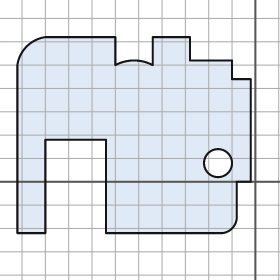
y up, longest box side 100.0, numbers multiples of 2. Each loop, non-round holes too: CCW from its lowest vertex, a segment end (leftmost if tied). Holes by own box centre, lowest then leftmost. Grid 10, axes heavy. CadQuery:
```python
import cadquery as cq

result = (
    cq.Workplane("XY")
    .moveTo(-102.0, -22.0)
    .lineTo(-90.0, -22.0)
    .lineTo(-90.0, 18.0)
    .lineTo(-64.0, 18.0)
    .lineTo(-64.0, -22.0)
    .lineTo(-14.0, -22.0)
    .threePointArc((-10.0, -20.0), (-8.0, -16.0))
    .lineTo(-8.0, 0.0)
    .lineTo(-2.0, 0.0)
    .lineTo(-2.0, 44.0)
    .lineTo(-10.0, 44.0)
    .lineTo(-10.0, 52.0)
    .lineTo(-28.0, 52.0)
    .lineTo(-28.0, 62.0)
    .lineTo(-44.0, 62.0)
    .lineTo(-44.0, 50.0)
    .threePointArc((-52.0, 52.0), (-60.0, 50.0))
    .lineTo(-60.0, 62.0)
    .lineTo(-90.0, 62.0)
    .threePointArc((-98.0, 58.0), (-102.0, 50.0))
    .close()
    .moveTo(-16.0, 8.0)
    .circle(6.0)
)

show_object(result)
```